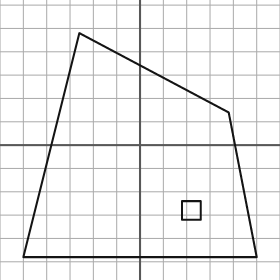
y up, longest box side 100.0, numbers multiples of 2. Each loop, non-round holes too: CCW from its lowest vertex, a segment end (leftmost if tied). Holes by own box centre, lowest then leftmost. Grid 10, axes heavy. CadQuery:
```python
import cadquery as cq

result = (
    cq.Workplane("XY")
    .moveTo(-50.0, -48.0)
    .lineTo(50.0, -48.0)
    .lineTo(38.0, 14.0)
    .lineTo(-26.0, 48.0)
    .close()
    .moveTo(18.0, -32.0)
    .lineTo(26.0, -32.0)
    .lineTo(26.0, -24.0)
    .lineTo(18.0, -24.0)
    .close()
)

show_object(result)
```